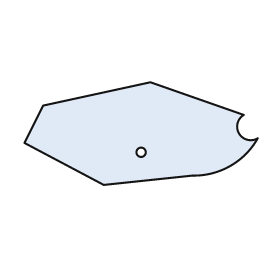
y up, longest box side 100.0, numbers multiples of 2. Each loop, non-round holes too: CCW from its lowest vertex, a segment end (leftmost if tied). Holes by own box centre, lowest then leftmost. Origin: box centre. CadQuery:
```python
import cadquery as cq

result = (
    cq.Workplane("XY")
    .moveTo(-16.0, -22.0)
    .lineTo(22.0, -18.0)
    .threePointArc((38.0, -14.0), (50.0, -2.0))
    .threePointArc((42.0, 0.0), (44.0, 8.0))
    .lineTo(4.0, 22.0)
    .lineTo(-42.0, 12.0)
    .lineTo(-50.0, -4.0)
    .close()
    .moveTo(0.0, -8.0)
    .circle(2.0)
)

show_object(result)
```